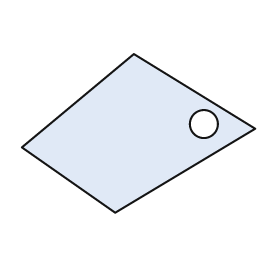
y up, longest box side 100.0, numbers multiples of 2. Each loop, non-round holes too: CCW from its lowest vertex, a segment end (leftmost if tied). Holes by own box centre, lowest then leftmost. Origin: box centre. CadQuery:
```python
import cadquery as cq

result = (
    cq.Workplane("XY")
    .moveTo(-10.0, -34.0)
    .lineTo(50.0, 2.0)
    .lineTo(-2.0, 34.0)
    .lineTo(-50.0, -6.0)
    .close()
    .moveTo(28.0, 4.0)
    .circle(6.0)
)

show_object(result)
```